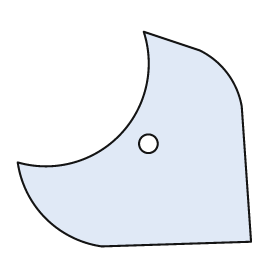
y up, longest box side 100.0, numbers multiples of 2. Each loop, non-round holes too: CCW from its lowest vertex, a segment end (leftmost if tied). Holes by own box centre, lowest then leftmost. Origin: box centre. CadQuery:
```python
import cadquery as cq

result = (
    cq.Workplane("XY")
    .moveTo(-14.0, -46.0)
    .lineTo(50.0, -44.0)
    .lineTo(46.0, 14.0)
    .threePointArc((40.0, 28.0), (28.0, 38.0))
    .lineTo(4.0, 46.0)
    .threePointArc((-6.0, 2.0), (-50.0, -10.0))
    .threePointArc((-38.0, -34.0), (-14.0, -46.0))
    .close()
    .moveTo(6.0, -2.0)
    .circle(4.0)
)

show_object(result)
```